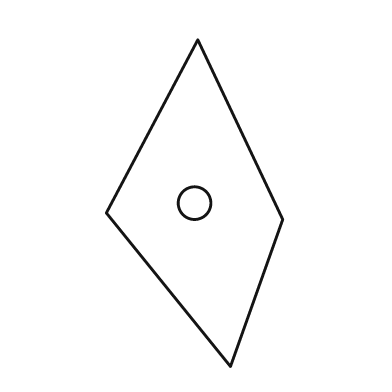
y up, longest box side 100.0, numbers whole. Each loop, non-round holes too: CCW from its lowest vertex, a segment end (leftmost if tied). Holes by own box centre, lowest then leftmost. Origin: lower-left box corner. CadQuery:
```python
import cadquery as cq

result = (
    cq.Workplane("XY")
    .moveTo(38.0, 0.0)
    .lineTo(54.0, 45.0)
    .lineTo(28.0, 100.0)
    .lineTo(0.0, 47.0)
    .close()
    .moveTo(27.0, 50.0)
    .circle(5.0)
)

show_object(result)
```